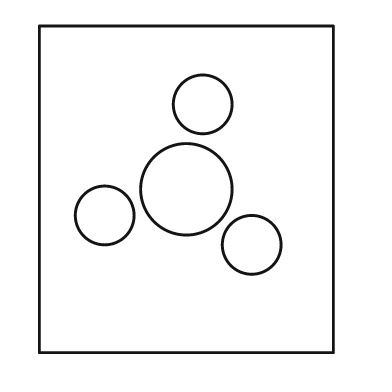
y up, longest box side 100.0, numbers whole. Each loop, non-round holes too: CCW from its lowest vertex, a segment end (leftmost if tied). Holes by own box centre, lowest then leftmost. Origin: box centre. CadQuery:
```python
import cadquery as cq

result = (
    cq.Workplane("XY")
    .moveTo(-45.0, -50.0)
    .lineTo(45.0, -50.0)
    .lineTo(45.0, 50.0)
    .lineTo(-45.0, 50.0)
    .close()
    .moveTo(20.0, -17.0)
    .circle(9.0)
    .moveTo(-25.0, -8.0)
    .circle(9.0)
    .moveTo(0.0, 0.0)
    .circle(14.0)
    .moveTo(5.0, 26.0)
    .circle(9.0)
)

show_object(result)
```